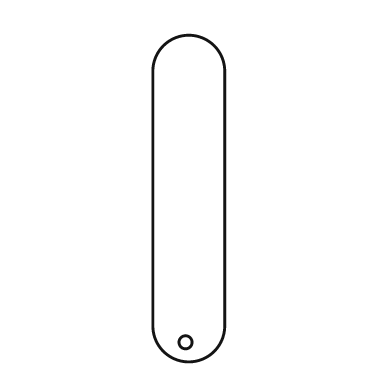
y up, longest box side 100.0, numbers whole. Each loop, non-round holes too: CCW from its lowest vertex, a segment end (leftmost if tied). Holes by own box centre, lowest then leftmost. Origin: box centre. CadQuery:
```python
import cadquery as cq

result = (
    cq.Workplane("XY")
    .moveTo(-11.0, -39.0)
    .threePointArc((0.0, -50.0), (11.0, -39.0))
    .lineTo(11.0, 39.0)
    .threePointArc((0.0, 50.0), (-11.0, 39.0))
    .close()
    .moveTo(-1.0, -44.0)
    .circle(2.0)
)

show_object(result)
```